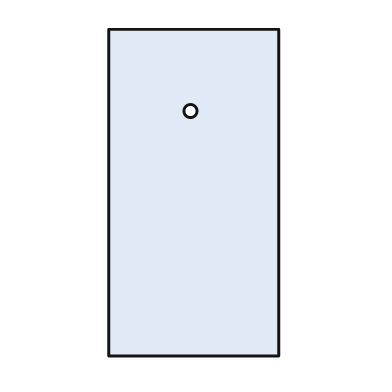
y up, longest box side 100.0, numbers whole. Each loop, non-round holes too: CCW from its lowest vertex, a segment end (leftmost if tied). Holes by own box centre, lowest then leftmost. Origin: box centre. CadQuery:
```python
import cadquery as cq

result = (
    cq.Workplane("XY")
    .moveTo(-26.0, -50.0)
    .lineTo(26.0, -50.0)
    .lineTo(26.0, 50.0)
    .lineTo(-26.0, 50.0)
    .close()
    .moveTo(-1.0, 25.0)
    .circle(2.0)
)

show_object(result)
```